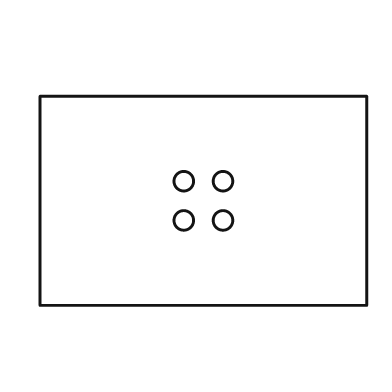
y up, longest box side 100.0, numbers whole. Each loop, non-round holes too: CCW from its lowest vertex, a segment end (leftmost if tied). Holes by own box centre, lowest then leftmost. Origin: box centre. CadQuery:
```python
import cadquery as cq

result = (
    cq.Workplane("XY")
    .moveTo(-50.0, -32.0)
    .lineTo(50.0, -32.0)
    .lineTo(50.0, 32.0)
    .lineTo(-50.0, 32.0)
    .close()
    .moveTo(-6.0, -6.0)
    .circle(3.0)
    .moveTo(6.0, -6.0)
    .circle(3.0)
    .moveTo(-6.0, 6.0)
    .circle(3.0)
    .moveTo(6.0, 6.0)
    .circle(3.0)
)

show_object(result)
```